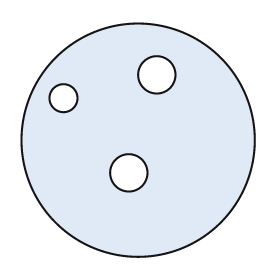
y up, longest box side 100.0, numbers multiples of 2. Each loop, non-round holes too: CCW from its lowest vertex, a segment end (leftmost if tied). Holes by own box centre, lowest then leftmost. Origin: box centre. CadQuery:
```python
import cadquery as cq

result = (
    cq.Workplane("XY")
    .moveTo(0.0, 0.0)
    .circle(50.0)
    .moveTo(-4.0, -14.0)
    .circle(8.0)
    .moveTo(-32.0, 18.0)
    .circle(6.0)
    .moveTo(8.0, 28.0)
    .circle(8.0)
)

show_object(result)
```